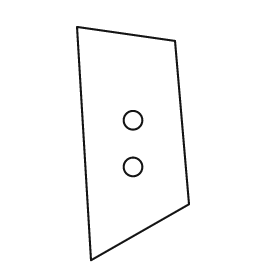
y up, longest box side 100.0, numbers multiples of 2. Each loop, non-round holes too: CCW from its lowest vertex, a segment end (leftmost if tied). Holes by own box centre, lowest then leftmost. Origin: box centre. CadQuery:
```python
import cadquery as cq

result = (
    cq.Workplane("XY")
    .moveTo(-18.0, -50.0)
    .lineTo(24.0, -26.0)
    .lineTo(18.0, 44.0)
    .lineTo(-24.0, 50.0)
    .close()
    .moveTo(0.0, -10.0)
    .circle(4.0)
    .moveTo(0.0, 10.0)
    .circle(4.0)
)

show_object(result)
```